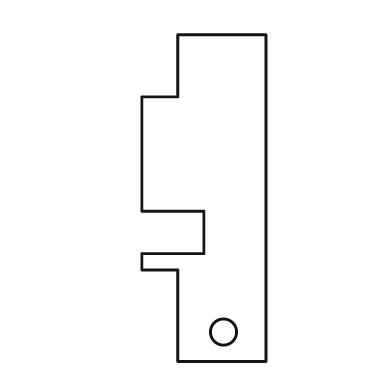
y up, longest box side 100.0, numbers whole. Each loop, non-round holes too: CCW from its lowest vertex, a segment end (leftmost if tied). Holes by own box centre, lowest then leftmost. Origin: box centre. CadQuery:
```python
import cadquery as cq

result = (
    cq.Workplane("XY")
    .moveTo(-8.0, -50.0)
    .lineTo(19.0, -50.0)
    .lineTo(19.0, 50.0)
    .lineTo(-8.0, 50.0)
    .lineTo(-8.0, 31.0)
    .lineTo(-19.0, 31.0)
    .lineTo(-19.0, -4.0)
    .lineTo(0.0, -4.0)
    .lineTo(0.0, -17.0)
    .lineTo(-19.0, -17.0)
    .lineTo(-19.0, -22.0)
    .lineTo(-8.0, -22.0)
    .close()
    .moveTo(6.0, -41.0)
    .circle(4.0)
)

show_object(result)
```